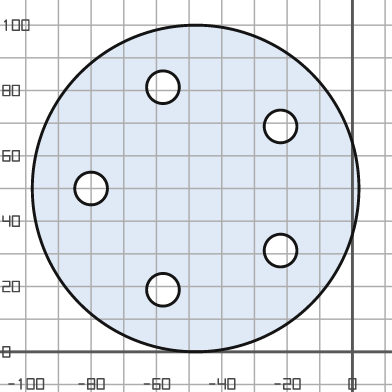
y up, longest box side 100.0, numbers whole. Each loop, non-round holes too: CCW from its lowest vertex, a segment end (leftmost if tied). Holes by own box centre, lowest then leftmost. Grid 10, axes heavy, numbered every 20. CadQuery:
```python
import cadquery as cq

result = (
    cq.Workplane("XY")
    .moveTo(-48.0, 50.0)
    .circle(50.0)
    .moveTo(-58.0, 19.0)
    .circle(5.0)
    .moveTo(-22.0, 31.0)
    .circle(5.0)
    .moveTo(-80.0, 50.0)
    .circle(5.0)
    .moveTo(-22.0, 69.0)
    .circle(5.0)
    .moveTo(-58.0, 81.0)
    .circle(5.0)
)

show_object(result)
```